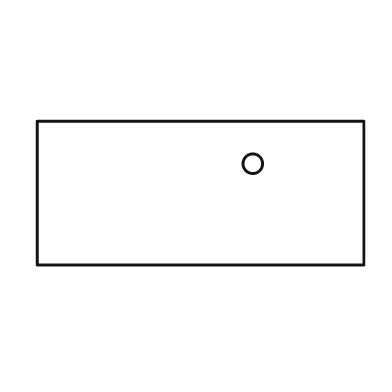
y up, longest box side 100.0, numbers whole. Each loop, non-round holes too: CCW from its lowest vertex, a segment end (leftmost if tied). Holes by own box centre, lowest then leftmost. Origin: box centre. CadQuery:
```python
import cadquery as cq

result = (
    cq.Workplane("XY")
    .moveTo(-50.0, -22.0)
    .lineTo(50.0, -22.0)
    .lineTo(50.0, 22.0)
    .lineTo(-50.0, 22.0)
    .close()
    .moveTo(16.0, 9.0)
    .circle(3.0)
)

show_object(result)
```